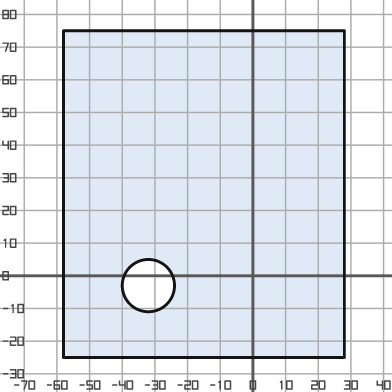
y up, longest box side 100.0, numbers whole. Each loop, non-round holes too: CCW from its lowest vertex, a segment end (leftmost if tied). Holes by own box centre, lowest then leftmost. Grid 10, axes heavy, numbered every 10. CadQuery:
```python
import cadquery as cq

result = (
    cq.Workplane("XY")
    .moveTo(-58.0, -25.0)
    .lineTo(28.0, -25.0)
    .lineTo(28.0, 75.0)
    .lineTo(-58.0, 75.0)
    .close()
    .moveTo(-32.0, -3.0)
    .circle(8.0)
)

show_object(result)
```